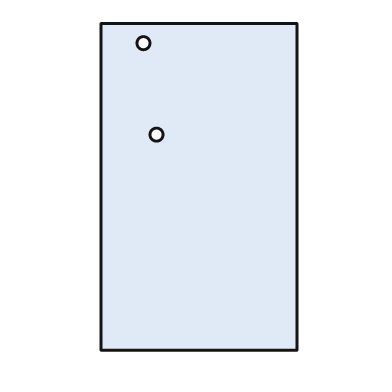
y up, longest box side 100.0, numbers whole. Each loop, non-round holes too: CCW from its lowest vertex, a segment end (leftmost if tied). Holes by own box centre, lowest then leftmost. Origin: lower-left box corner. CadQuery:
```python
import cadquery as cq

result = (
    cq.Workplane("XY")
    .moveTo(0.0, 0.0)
    .lineTo(60.0, 0.0)
    .lineTo(60.0, 100.0)
    .lineTo(0.0, 100.0)
    .close()
    .moveTo(17.0, 66.0)
    .circle(2.0)
    .moveTo(13.0, 94.0)
    .circle(2.0)
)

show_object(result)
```